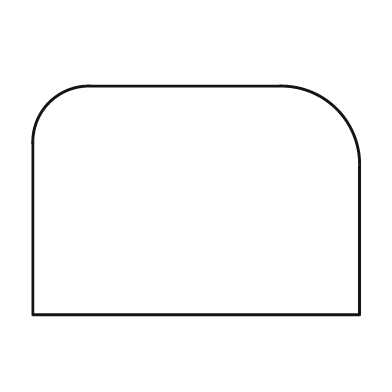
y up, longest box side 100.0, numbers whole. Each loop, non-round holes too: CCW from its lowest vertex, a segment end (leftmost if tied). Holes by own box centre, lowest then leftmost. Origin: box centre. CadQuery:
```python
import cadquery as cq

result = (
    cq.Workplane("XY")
    .moveTo(-50.0, -35.0)
    .lineTo(50.0, -35.0)
    .lineTo(50.0, 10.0)
    .threePointArc((43.0, 28.0), (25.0, 35.0))
    .lineTo(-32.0, 35.0)
    .threePointArc((-45.0, 30.0), (-50.0, 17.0))
    .close()
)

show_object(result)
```